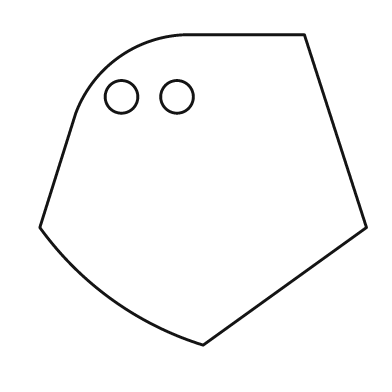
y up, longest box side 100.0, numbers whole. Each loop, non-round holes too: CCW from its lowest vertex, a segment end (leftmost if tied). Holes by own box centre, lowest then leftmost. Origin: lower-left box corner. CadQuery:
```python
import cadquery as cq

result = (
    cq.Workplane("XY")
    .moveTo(50.0, 0.0)
    .lineTo(100.0, 36.0)
    .lineTo(81.0, 95.0)
    .lineTo(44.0, 95.0)
    .threePointArc((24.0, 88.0), (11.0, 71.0))
    .lineTo(0.0, 36.0)
    .threePointArc((22.0, 14.0), (50.0, 0.0))
    .close()
    .moveTo(25.0, 76.0)
    .circle(5.0)
    .moveTo(42.0, 76.0)
    .circle(5.0)
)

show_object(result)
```